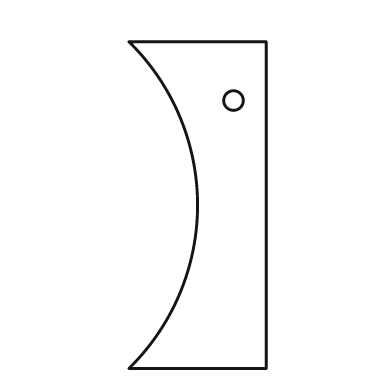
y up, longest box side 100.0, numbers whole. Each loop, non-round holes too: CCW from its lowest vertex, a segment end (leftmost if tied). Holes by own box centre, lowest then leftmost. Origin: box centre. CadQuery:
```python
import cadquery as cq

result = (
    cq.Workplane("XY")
    .moveTo(-21.0, -50.0)
    .lineTo(21.0, -50.0)
    .lineTo(21.0, 50.0)
    .lineTo(-21.0, 50.0)
    .threePointArc((0.0, 0.0), (-21.0, -50.0))
    .close()
    .moveTo(11.0, 32.0)
    .circle(3.0)
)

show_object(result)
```